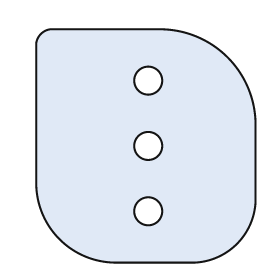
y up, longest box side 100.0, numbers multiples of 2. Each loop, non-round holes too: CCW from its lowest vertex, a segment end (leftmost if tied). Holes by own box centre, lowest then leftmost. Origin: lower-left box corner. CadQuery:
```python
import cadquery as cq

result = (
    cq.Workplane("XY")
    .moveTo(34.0, 0.0)
    .lineTo(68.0, 0.0)
    .threePointArc((86.0, 8.0), (94.0, 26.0))
    .lineTo(94.0, 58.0)
    .threePointArc((82.0, 88.0), (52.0, 100.0))
    .lineTo(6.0, 100.0)
    .threePointArc((2.0, 98.0), (0.0, 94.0))
    .lineTo(0.0, 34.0)
    .threePointArc((10.0, 10.0), (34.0, 0.0))
    .close()
    .moveTo(48.0, 22.0)
    .circle(6.0)
    .moveTo(48.0, 50.0)
    .circle(6.0)
    .moveTo(48.0, 78.0)
    .circle(6.0)
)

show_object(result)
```